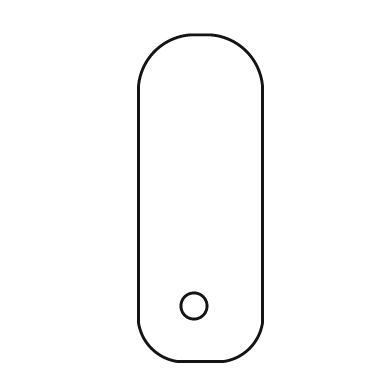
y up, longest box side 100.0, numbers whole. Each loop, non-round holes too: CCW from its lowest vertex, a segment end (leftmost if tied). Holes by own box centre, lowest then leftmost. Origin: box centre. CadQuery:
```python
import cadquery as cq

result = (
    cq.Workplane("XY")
    .moveTo(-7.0, -50.0)
    .lineTo(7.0, -50.0)
    .threePointArc((15.0, -46.0), (19.0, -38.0))
    .lineTo(19.0, 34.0)
    .threePointArc((14.0, 45.0), (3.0, 50.0))
    .lineTo(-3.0, 50.0)
    .threePointArc((-14.0, 45.0), (-19.0, 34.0))
    .lineTo(-19.0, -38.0)
    .threePointArc((-15.0, -46.0), (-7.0, -50.0))
    .close()
    .moveTo(-2.0, -33.0)
    .circle(4.0)
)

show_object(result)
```